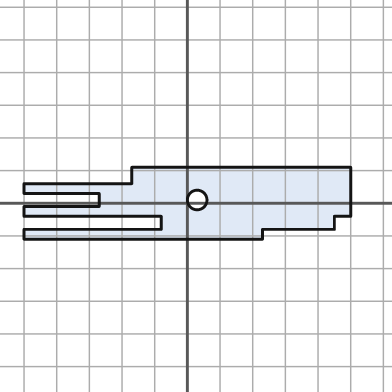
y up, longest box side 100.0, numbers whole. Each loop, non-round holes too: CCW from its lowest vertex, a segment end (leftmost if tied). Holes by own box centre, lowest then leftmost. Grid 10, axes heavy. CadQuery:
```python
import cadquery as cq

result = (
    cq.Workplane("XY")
    .moveTo(-50.0, -11.0)
    .lineTo(23.0, -11.0)
    .lineTo(23.0, -8.0)
    .lineTo(45.0, -8.0)
    .lineTo(45.0, -4.0)
    .lineTo(50.0, -4.0)
    .lineTo(50.0, 11.0)
    .lineTo(-17.0, 11.0)
    .lineTo(-17.0, 6.0)
    .lineTo(-50.0, 6.0)
    .lineTo(-50.0, 3.0)
    .lineTo(-27.0, 3.0)
    .lineTo(-27.0, -1.0)
    .lineTo(-50.0, -1.0)
    .lineTo(-50.0, -4.0)
    .lineTo(-8.0, -4.0)
    .lineTo(-8.0, -8.0)
    .lineTo(-50.0, -8.0)
    .close()
    .moveTo(3.0, 1.0)
    .circle(3.0)
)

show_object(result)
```